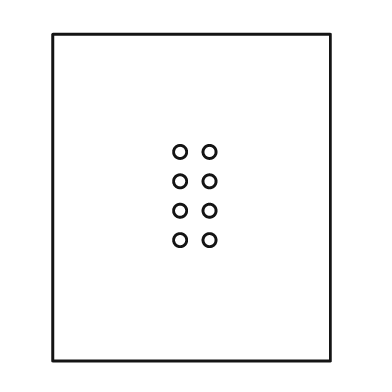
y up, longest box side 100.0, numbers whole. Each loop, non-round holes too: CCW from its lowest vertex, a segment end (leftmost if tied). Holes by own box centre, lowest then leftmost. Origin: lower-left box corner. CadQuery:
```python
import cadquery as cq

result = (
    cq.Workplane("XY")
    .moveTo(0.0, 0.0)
    .lineTo(85.0, 0.0)
    .lineTo(85.0, 100.0)
    .lineTo(0.0, 100.0)
    .close()
    .moveTo(39.0, 37.0)
    .circle(2.0)
    .moveTo(48.0, 37.0)
    .circle(2.0)
    .moveTo(39.0, 46.0)
    .circle(2.0)
    .moveTo(48.0, 46.0)
    .circle(2.0)
    .moveTo(39.0, 55.0)
    .circle(2.0)
    .moveTo(48.0, 55.0)
    .circle(2.0)
    .moveTo(39.0, 64.0)
    .circle(2.0)
    .moveTo(48.0, 64.0)
    .circle(2.0)
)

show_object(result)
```